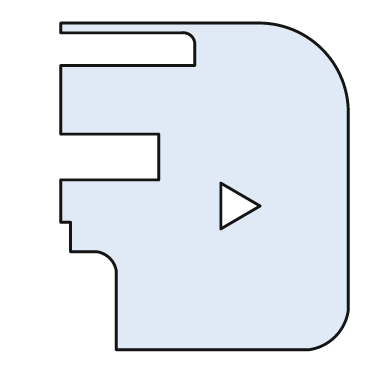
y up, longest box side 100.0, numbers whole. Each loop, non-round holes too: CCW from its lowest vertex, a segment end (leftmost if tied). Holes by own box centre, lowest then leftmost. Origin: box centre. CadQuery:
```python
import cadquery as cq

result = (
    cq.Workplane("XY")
    .moveTo(-27.0, -50.0)
    .lineTo(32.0, -50.0)
    .threePointArc((40.0, -46.0), (44.0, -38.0))
    .lineTo(44.0, 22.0)
    .threePointArc((36.0, 42.0), (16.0, 50.0))
    .lineTo(-44.0, 50.0)
    .lineTo(-44.0, 47.0)
    .lineTo(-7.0, 47.0)
    .threePointArc((-4.0, 46.0), (-3.0, 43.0))
    .lineTo(-3.0, 37.0)
    .lineTo(-44.0, 37.0)
    .lineTo(-44.0, 16.0)
    .lineTo(-14.0, 16.0)
    .lineTo(-14.0, 2.0)
    .lineTo(-44.0, 2.0)
    .lineTo(-44.0, -11.0)
    .lineTo(-41.0, -11.0)
    .lineTo(-41.0, -20.0)
    .lineTo(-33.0, -20.0)
    .threePointArc((-29.0, -22.0), (-27.0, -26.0))
    .close()
    .moveTo(5.0, -13.0)
    .lineTo(17.0, -6.0)
    .lineTo(5.0, 1.0)
    .close()
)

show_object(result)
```